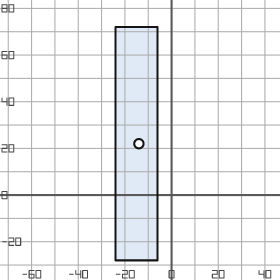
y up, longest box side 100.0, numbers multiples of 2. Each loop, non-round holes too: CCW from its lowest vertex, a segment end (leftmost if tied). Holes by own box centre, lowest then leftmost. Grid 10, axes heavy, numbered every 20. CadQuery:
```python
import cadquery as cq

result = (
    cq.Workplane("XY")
    .moveTo(-24.0, -28.0)
    .lineTo(-6.0, -28.0)
    .lineTo(-6.0, 72.0)
    .lineTo(-24.0, 72.0)
    .close()
    .moveTo(-14.0, 22.0)
    .circle(2.0)
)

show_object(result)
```